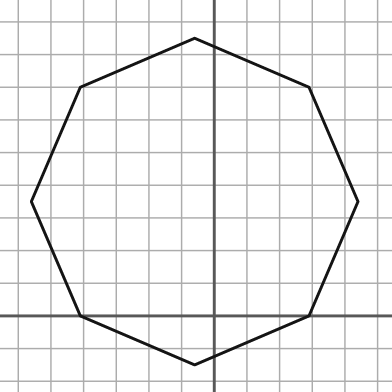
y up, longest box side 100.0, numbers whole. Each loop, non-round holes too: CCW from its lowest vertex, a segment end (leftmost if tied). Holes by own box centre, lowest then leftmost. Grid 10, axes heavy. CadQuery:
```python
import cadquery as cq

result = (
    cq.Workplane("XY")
    .moveTo(-6.0, -15.0)
    .lineTo(29.0, 0.0)
    .lineTo(44.0, 35.0)
    .lineTo(29.0, 70.0)
    .lineTo(-6.0, 85.0)
    .lineTo(-41.0, 70.0)
    .lineTo(-56.0, 35.0)
    .lineTo(-41.0, 0.0)
    .close()
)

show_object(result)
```